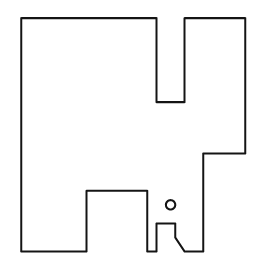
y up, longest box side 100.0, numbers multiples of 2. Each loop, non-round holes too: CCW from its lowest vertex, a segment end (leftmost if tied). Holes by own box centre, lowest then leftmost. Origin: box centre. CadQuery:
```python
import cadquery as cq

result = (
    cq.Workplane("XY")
    .moveTo(-48.0, -50.0)
    .lineTo(-20.0, -50.0)
    .lineTo(-20.0, -24.0)
    .lineTo(6.0, -24.0)
    .lineTo(6.0, -50.0)
    .lineTo(10.0, -50.0)
    .lineTo(10.0, -38.0)
    .lineTo(18.0, -38.0)
    .lineTo(18.0, -44.0)
    .lineTo(22.0, -50.0)
    .lineTo(30.0, -50.0)
    .lineTo(30.0, -8.0)
    .lineTo(48.0, -8.0)
    .lineTo(48.0, 50.0)
    .lineTo(22.0, 50.0)
    .lineTo(22.0, 14.0)
    .lineTo(10.0, 14.0)
    .lineTo(10.0, 50.0)
    .lineTo(-48.0, 50.0)
    .close()
    .moveTo(16.0, -30.0)
    .circle(2.0)
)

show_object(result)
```